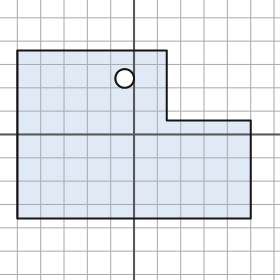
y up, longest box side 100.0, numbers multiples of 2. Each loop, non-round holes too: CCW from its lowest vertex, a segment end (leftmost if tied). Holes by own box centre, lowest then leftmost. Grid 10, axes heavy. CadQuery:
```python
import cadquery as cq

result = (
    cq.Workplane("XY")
    .moveTo(-50.0, -36.0)
    .lineTo(50.0, -36.0)
    .lineTo(50.0, 6.0)
    .lineTo(14.0, 6.0)
    .lineTo(14.0, 36.0)
    .lineTo(-50.0, 36.0)
    .close()
    .moveTo(-4.0, 24.0)
    .circle(4.0)
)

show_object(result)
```